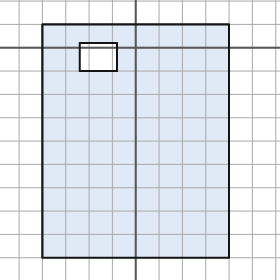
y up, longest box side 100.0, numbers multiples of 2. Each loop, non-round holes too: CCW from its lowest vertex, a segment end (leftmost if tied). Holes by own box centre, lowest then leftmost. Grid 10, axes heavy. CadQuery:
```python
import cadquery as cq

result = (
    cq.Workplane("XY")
    .moveTo(-40.0, -90.0)
    .lineTo(40.0, -90.0)
    .lineTo(40.0, 10.0)
    .lineTo(-40.0, 10.0)
    .close()
    .moveTo(-24.0, -10.0)
    .lineTo(-8.0, -10.0)
    .lineTo(-8.0, 2.0)
    .lineTo(-24.0, 2.0)
    .close()
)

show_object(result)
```